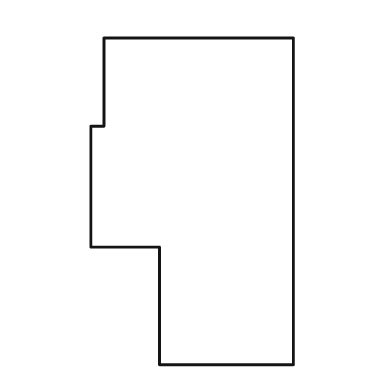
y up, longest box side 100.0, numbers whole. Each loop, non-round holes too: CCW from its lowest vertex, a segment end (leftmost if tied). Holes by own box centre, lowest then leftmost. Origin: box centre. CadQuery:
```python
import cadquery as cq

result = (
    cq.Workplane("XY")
    .moveTo(-10.0, -50.0)
    .lineTo(31.0, -50.0)
    .lineTo(31.0, 50.0)
    .lineTo(-27.0, 50.0)
    .lineTo(-27.0, 23.0)
    .lineTo(-31.0, 23.0)
    .lineTo(-31.0, -14.0)
    .lineTo(-10.0, -14.0)
    .close()
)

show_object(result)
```